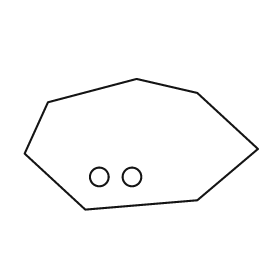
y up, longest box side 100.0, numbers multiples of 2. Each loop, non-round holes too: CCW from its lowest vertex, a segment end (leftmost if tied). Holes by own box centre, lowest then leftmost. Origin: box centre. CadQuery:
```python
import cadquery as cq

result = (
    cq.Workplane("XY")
    .moveTo(-24.0, -28.0)
    .lineTo(24.0, -24.0)
    .lineTo(50.0, -2.0)
    .lineTo(24.0, 22.0)
    .lineTo(-2.0, 28.0)
    .lineTo(-40.0, 18.0)
    .lineTo(-50.0, -4.0)
    .close()
    .moveTo(-18.0, -14.0)
    .circle(4.0)
    .moveTo(-4.0, -14.0)
    .circle(4.0)
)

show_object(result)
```